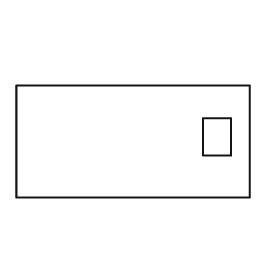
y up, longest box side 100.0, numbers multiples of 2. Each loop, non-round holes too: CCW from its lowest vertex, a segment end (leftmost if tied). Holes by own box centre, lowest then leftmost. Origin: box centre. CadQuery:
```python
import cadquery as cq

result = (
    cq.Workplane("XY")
    .moveTo(-50.0, -24.0)
    .lineTo(50.0, -24.0)
    .lineTo(50.0, 24.0)
    .lineTo(-50.0, 24.0)
    .close()
    .moveTo(30.0, -6.0)
    .lineTo(42.0, -6.0)
    .lineTo(42.0, 10.0)
    .lineTo(30.0, 10.0)
    .close()
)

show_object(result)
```